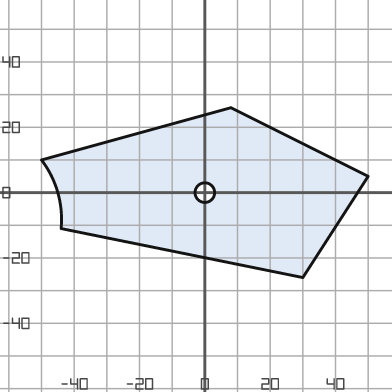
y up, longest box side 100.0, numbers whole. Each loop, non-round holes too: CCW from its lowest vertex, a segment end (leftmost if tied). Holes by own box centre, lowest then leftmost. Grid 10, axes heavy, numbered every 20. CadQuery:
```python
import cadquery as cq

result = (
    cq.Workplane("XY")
    .moveTo(30.0, -26.0)
    .lineTo(50.0, 5.0)
    .lineTo(8.0, 26.0)
    .lineTo(-50.0, 10.0)
    .threePointArc((-45.0, 0.0), (-44.0, -11.0))
    .close()
    .moveTo(0.0, 0.0)
    .circle(3.0)
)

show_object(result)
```